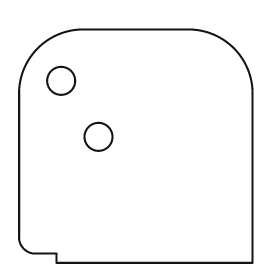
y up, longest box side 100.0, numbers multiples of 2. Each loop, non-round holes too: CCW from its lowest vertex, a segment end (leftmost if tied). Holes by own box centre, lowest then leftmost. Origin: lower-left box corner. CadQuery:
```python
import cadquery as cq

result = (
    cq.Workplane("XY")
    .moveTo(16.0, 0.0)
    .lineTo(100.0, 0.0)
    .lineTo(100.0, 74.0)
    .threePointArc((92.0, 92.0), (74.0, 100.0))
    .lineTo(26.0, 100.0)
    .threePointArc((8.0, 92.0), (0.0, 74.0))
    .lineTo(0.0, 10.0)
    .threePointArc((2.0, 6.0), (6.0, 4.0))
    .lineTo(16.0, 4.0)
    .close()
    .moveTo(34.0, 54.0)
    .circle(6.0)
    .moveTo(18.0, 78.0)
    .circle(6.0)
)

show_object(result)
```